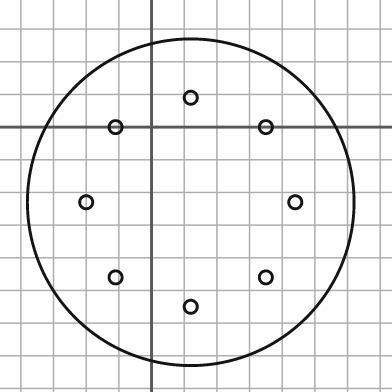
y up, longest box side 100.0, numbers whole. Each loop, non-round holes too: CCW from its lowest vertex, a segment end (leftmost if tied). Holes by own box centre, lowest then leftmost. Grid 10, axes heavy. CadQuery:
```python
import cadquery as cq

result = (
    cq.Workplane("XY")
    .moveTo(12.0, -23.0)
    .circle(50.0)
    .moveTo(12.0, -55.0)
    .circle(2.0)
    .moveTo(-11.0, -46.0)
    .circle(2.0)
    .moveTo(35.0, -46.0)
    .circle(2.0)
    .moveTo(-20.0, -23.0)
    .circle(2.0)
    .moveTo(44.0, -23.0)
    .circle(2.0)
    .moveTo(-11.0, 0.0)
    .circle(2.0)
    .moveTo(35.0, 0.0)
    .circle(2.0)
    .moveTo(12.0, 9.0)
    .circle(2.0)
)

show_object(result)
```